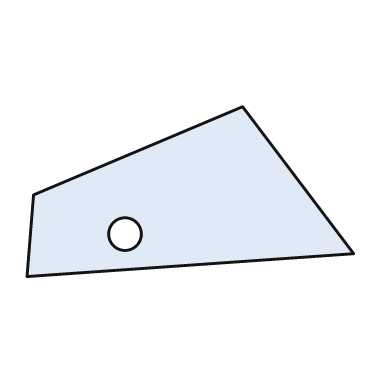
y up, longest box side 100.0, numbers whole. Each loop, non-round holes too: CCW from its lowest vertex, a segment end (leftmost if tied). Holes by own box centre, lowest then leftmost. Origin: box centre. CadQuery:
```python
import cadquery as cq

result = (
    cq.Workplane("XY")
    .moveTo(-50.0, -26.0)
    .lineTo(50.0, -19.0)
    .lineTo(16.0, 26.0)
    .lineTo(-48.0, -1.0)
    .close()
    .moveTo(-20.0, -13.0)
    .circle(5.0)
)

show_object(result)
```